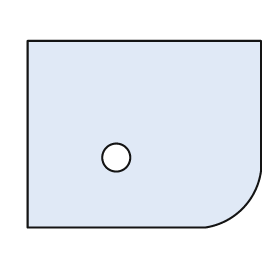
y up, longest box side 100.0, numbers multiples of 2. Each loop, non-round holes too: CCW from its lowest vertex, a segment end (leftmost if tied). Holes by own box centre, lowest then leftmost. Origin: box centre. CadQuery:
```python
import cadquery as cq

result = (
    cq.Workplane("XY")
    .moveTo(-50.0, -40.0)
    .lineTo(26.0, -40.0)
    .threePointArc((42.0, -32.0), (50.0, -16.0))
    .lineTo(50.0, 40.0)
    .lineTo(-50.0, 40.0)
    .close()
    .moveTo(-12.0, -10.0)
    .circle(6.0)
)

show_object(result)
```